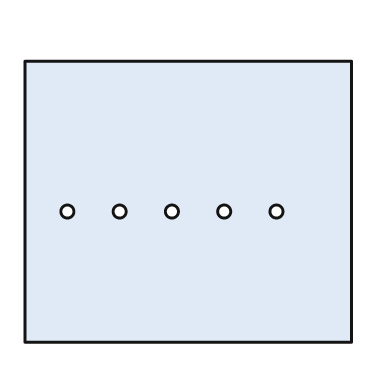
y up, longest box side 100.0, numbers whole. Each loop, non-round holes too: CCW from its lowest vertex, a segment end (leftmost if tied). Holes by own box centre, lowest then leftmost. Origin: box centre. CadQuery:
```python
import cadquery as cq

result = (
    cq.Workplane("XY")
    .moveTo(-50.0, -43.0)
    .lineTo(50.0, -43.0)
    .lineTo(50.0, 43.0)
    .lineTo(-50.0, 43.0)
    .close()
    .moveTo(-37.0, -3.0)
    .circle(2.0)
    .moveTo(-21.0, -3.0)
    .circle(2.0)
    .moveTo(-5.0, -3.0)
    .circle(2.0)
    .moveTo(11.0, -3.0)
    .circle(2.0)
    .moveTo(27.0, -3.0)
    .circle(2.0)
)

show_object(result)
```